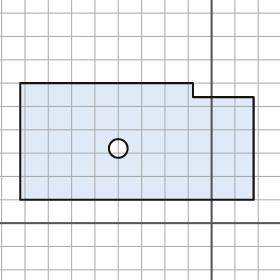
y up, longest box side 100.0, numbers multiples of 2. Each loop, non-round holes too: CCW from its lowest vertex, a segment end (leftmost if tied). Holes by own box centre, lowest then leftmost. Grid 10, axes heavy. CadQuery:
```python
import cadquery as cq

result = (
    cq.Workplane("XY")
    .moveTo(-82.0, 10.0)
    .lineTo(18.0, 10.0)
    .lineTo(18.0, 54.0)
    .lineTo(-8.0, 54.0)
    .lineTo(-8.0, 60.0)
    .lineTo(-82.0, 60.0)
    .close()
    .moveTo(-40.0, 32.0)
    .circle(4.0)
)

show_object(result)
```